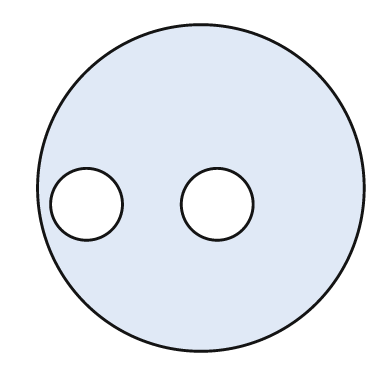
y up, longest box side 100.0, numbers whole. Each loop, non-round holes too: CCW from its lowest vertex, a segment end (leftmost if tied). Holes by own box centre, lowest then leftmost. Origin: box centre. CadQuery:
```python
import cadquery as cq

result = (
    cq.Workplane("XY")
    .moveTo(0.0, 0.0)
    .circle(50.0)
    .moveTo(-35.0, -5.0)
    .circle(11.0)
    .moveTo(5.0, -5.0)
    .circle(11.0)
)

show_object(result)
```